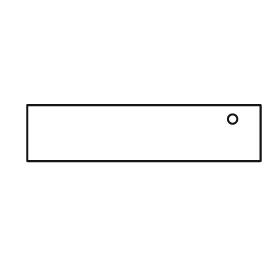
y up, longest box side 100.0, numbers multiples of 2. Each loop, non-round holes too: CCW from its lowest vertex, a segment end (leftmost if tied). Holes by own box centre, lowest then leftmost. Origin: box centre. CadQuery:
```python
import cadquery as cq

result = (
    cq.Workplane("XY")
    .moveTo(-50.0, -12.0)
    .lineTo(50.0, -12.0)
    .lineTo(50.0, 12.0)
    .lineTo(-50.0, 12.0)
    .close()
    .moveTo(38.0, 6.0)
    .circle(2.0)
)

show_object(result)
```